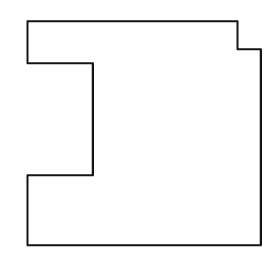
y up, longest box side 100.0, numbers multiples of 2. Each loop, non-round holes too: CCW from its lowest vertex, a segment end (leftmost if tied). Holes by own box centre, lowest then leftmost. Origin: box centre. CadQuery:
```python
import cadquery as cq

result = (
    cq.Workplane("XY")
    .moveTo(-50.0, -48.0)
    .lineTo(50.0, -48.0)
    .lineTo(50.0, 36.0)
    .lineTo(40.0, 36.0)
    .lineTo(40.0, 48.0)
    .lineTo(-50.0, 48.0)
    .lineTo(-50.0, 30.0)
    .lineTo(-22.0, 30.0)
    .lineTo(-22.0, -18.0)
    .lineTo(-50.0, -18.0)
    .close()
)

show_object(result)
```